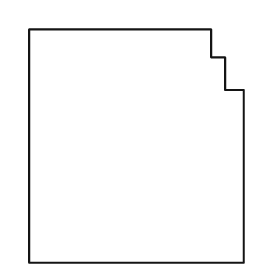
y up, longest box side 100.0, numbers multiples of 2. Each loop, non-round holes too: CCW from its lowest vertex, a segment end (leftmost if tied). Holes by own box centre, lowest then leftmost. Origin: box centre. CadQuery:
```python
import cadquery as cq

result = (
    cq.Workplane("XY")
    .moveTo(-46.0, -50.0)
    .lineTo(46.0, -50.0)
    .lineTo(46.0, 24.0)
    .lineTo(38.0, 24.0)
    .lineTo(38.0, 38.0)
    .lineTo(32.0, 38.0)
    .lineTo(32.0, 50.0)
    .lineTo(-46.0, 50.0)
    .close()
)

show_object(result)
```